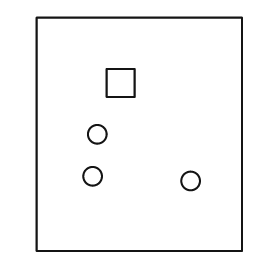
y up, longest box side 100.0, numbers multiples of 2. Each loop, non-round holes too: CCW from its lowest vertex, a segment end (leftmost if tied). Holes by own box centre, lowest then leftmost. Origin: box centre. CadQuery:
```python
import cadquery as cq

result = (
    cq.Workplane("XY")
    .moveTo(-44.0, -50.0)
    .lineTo(44.0, -50.0)
    .lineTo(44.0, 50.0)
    .lineTo(-44.0, 50.0)
    .close()
    .moveTo(22.0, -20.0)
    .circle(4.0)
    .moveTo(-20.0, -18.0)
    .circle(4.0)
    .moveTo(-18.0, 0.0)
    .circle(4.0)
    .moveTo(-14.0, 16.0)
    .lineTo(-2.0, 16.0)
    .lineTo(-2.0, 28.0)
    .lineTo(-14.0, 28.0)
    .close()
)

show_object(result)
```